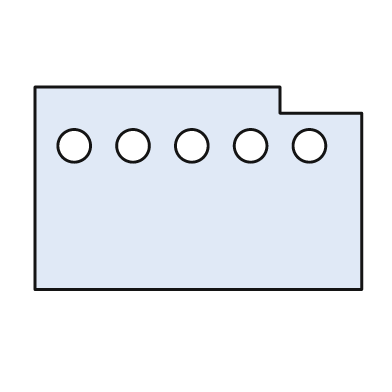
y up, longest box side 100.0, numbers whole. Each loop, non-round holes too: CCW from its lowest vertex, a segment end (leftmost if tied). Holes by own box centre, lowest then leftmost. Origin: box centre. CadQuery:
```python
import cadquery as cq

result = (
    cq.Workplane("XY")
    .moveTo(-50.0, -31.0)
    .lineTo(50.0, -31.0)
    .lineTo(50.0, 23.0)
    .lineTo(25.0, 23.0)
    .lineTo(25.0, 31.0)
    .lineTo(-50.0, 31.0)
    .close()
    .moveTo(-38.0, 13.0)
    .circle(5.0)
    .moveTo(-20.0, 13.0)
    .circle(5.0)
    .moveTo(-2.0, 13.0)
    .circle(5.0)
    .moveTo(16.0, 13.0)
    .circle(5.0)
    .moveTo(34.0, 13.0)
    .circle(5.0)
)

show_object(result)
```